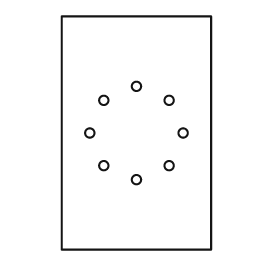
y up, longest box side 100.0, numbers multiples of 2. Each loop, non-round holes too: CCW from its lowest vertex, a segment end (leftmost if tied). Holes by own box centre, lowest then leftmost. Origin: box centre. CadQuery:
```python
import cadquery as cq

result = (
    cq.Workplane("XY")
    .moveTo(-32.0, -50.0)
    .lineTo(32.0, -50.0)
    .lineTo(32.0, 50.0)
    .lineTo(-32.0, 50.0)
    .close()
    .moveTo(0.0, -20.0)
    .circle(2.0)
    .moveTo(-14.0, -14.0)
    .circle(2.0)
    .moveTo(14.0, -14.0)
    .circle(2.0)
    .moveTo(-20.0, 0.0)
    .circle(2.0)
    .moveTo(20.0, 0.0)
    .circle(2.0)
    .moveTo(-14.0, 14.0)
    .circle(2.0)
    .moveTo(14.0, 14.0)
    .circle(2.0)
    .moveTo(0.0, 20.0)
    .circle(2.0)
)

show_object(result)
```